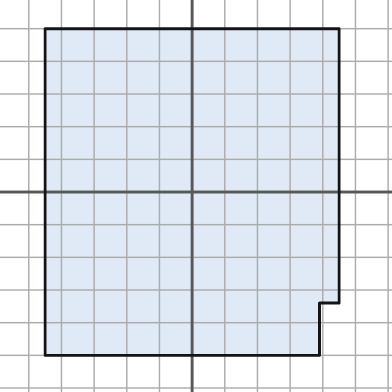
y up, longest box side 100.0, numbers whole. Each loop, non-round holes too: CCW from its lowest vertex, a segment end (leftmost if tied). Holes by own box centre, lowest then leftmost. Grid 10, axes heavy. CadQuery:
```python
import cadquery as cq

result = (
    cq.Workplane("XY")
    .moveTo(-45.0, -50.0)
    .lineTo(39.0, -50.0)
    .lineTo(39.0, -34.0)
    .lineTo(45.0, -34.0)
    .lineTo(45.0, 50.0)
    .lineTo(-45.0, 50.0)
    .close()
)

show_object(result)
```